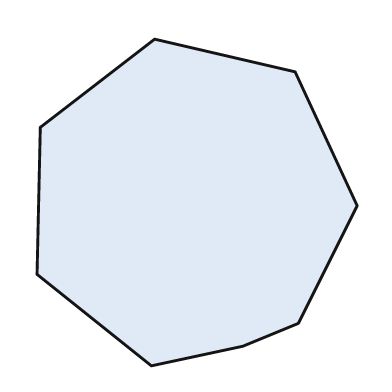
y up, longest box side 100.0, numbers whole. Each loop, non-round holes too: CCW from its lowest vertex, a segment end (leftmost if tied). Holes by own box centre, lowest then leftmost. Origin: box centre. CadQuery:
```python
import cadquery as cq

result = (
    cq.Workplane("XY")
    .moveTo(-14.0, -50.0)
    .lineTo(14.0, -44.0)
    .lineTo(31.0, -37.0)
    .lineTo(49.0, -1.0)
    .lineTo(30.0, 40.0)
    .lineTo(-13.0, 50.0)
    .lineTo(-48.0, 23.0)
    .lineTo(-49.0, -22.0)
    .close()
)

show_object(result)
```